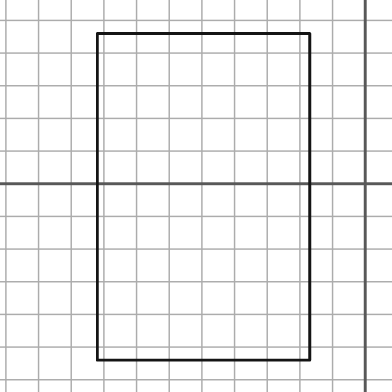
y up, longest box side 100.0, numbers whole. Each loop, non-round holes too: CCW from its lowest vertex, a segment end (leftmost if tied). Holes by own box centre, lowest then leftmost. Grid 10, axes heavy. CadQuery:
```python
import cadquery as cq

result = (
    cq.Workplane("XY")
    .moveTo(-82.0, -54.0)
    .lineTo(-17.0, -54.0)
    .lineTo(-17.0, 46.0)
    .lineTo(-82.0, 46.0)
    .close()
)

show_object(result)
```